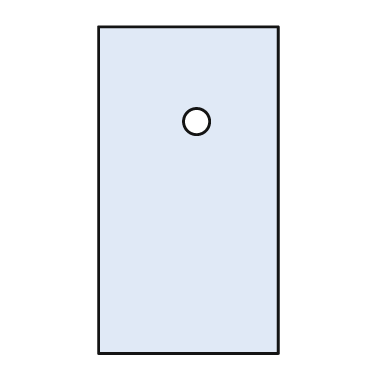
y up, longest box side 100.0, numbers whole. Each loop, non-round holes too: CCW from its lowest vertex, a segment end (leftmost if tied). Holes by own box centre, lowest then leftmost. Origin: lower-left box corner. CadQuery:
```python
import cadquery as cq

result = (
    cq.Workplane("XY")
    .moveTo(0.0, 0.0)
    .lineTo(55.0, 0.0)
    .lineTo(55.0, 100.0)
    .lineTo(0.0, 100.0)
    .close()
    .moveTo(30.0, 71.0)
    .circle(4.0)
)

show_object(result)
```